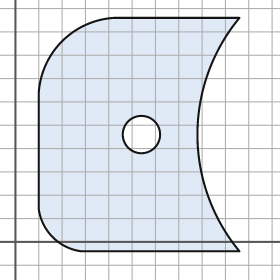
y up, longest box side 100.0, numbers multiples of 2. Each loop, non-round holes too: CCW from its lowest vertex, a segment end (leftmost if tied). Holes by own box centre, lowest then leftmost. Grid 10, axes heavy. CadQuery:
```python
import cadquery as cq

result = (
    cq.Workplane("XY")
    .moveTo(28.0, -4.0)
    .lineTo(96.0, -4.0)
    .threePointArc((78.0, 46.0), (96.0, 96.0))
    .lineTo(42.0, 96.0)
    .threePointArc((20.0, 86.0), (10.0, 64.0))
    .lineTo(10.0, 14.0)
    .threePointArc((16.0, 2.0), (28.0, -4.0))
    .close()
    .moveTo(54.0, 46.0)
    .circle(8.0)
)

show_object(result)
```